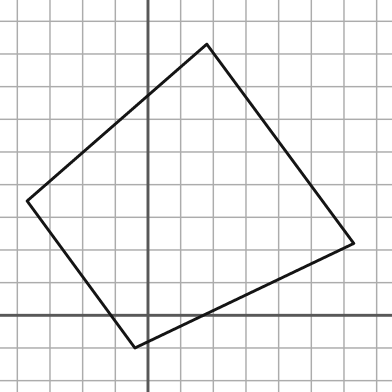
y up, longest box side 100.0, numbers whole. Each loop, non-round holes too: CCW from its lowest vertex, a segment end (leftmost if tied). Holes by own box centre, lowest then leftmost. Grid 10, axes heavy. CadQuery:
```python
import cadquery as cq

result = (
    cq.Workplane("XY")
    .moveTo(-4.0, -10.0)
    .lineTo(63.0, 22.0)
    .lineTo(18.0, 83.0)
    .lineTo(-37.0, 35.0)
    .close()
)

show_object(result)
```